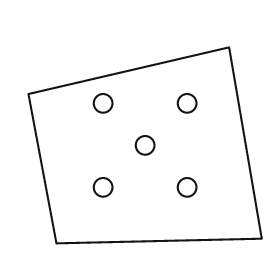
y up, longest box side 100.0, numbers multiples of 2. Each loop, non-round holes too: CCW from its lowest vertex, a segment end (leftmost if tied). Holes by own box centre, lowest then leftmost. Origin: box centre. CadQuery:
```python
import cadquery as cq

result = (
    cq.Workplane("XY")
    .moveTo(-38.0, -42.0)
    .lineTo(50.0, -40.0)
    .lineTo(36.0, 42.0)
    .lineTo(-50.0, 22.0)
    .close()
    .moveTo(-18.0, -18.0)
    .circle(4.0)
    .moveTo(18.0, -18.0)
    .circle(4.0)
    .moveTo(0.0, 0.0)
    .circle(4.0)
    .moveTo(-18.0, 18.0)
    .circle(4.0)
    .moveTo(18.0, 18.0)
    .circle(4.0)
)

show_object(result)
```